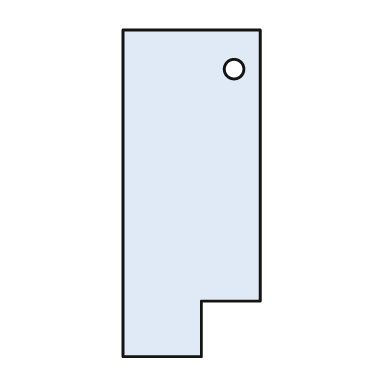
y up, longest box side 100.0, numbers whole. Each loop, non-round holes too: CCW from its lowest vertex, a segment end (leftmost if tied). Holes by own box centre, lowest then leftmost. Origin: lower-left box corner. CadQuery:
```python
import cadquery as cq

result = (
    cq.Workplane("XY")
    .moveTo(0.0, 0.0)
    .lineTo(24.0, 0.0)
    .lineTo(24.0, 17.0)
    .lineTo(42.0, 17.0)
    .lineTo(42.0, 100.0)
    .lineTo(0.0, 100.0)
    .close()
    .moveTo(34.0, 88.0)
    .circle(3.0)
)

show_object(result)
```